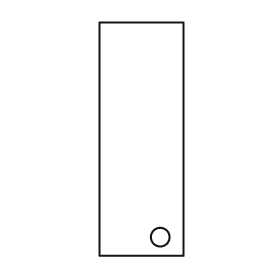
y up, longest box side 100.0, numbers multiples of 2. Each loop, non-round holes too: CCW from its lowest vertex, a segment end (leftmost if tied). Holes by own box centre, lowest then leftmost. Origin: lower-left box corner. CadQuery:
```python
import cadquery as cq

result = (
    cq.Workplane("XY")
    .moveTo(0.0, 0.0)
    .lineTo(36.0, 0.0)
    .lineTo(36.0, 100.0)
    .lineTo(0.0, 100.0)
    .close()
    .moveTo(26.0, 8.0)
    .circle(4.0)
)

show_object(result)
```